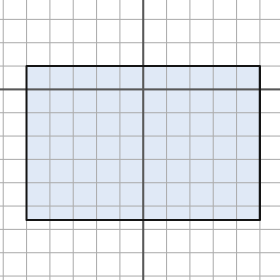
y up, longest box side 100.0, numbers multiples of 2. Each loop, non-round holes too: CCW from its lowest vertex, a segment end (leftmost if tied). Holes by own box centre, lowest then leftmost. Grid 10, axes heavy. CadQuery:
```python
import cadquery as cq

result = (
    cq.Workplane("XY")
    .moveTo(-50.0, -56.0)
    .lineTo(50.0, -56.0)
    .lineTo(50.0, 10.0)
    .lineTo(-50.0, 10.0)
    .close()
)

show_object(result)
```